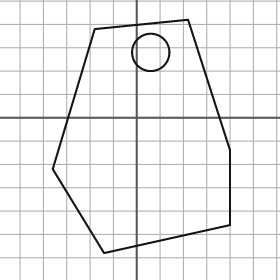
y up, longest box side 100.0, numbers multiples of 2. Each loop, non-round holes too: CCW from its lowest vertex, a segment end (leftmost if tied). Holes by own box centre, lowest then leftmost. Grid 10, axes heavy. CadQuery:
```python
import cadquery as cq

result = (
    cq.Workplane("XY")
    .moveTo(-14.0, -58.0)
    .lineTo(40.0, -46.0)
    .lineTo(40.0, -14.0)
    .lineTo(22.0, 42.0)
    .lineTo(-18.0, 38.0)
    .lineTo(-36.0, -22.0)
    .close()
    .moveTo(6.0, 28.0)
    .circle(8.0)
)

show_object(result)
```